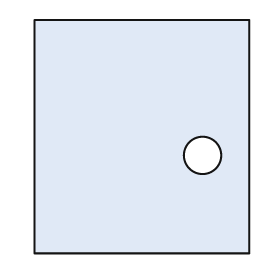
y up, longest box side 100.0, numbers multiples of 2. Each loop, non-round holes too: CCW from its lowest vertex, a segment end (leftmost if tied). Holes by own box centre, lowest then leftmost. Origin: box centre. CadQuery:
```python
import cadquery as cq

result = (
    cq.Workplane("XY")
    .moveTo(-46.0, -50.0)
    .lineTo(46.0, -50.0)
    .lineTo(46.0, 50.0)
    .lineTo(-46.0, 50.0)
    .close()
    .moveTo(26.0, -8.0)
    .circle(8.0)
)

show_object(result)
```